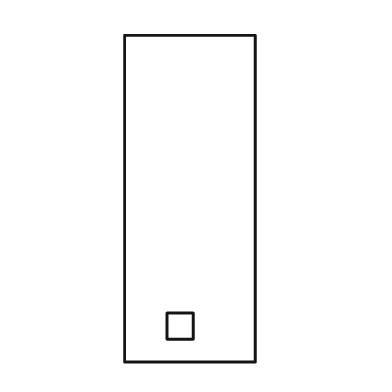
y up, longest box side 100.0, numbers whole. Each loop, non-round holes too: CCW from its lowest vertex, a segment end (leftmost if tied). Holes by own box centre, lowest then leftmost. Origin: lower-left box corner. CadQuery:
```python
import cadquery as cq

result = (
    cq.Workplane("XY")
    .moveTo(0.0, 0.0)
    .lineTo(40.0, 0.0)
    .lineTo(40.0, 100.0)
    .lineTo(0.0, 100.0)
    .close()
    .moveTo(13.0, 7.0)
    .lineTo(21.0, 7.0)
    .lineTo(21.0, 15.0)
    .lineTo(13.0, 15.0)
    .close()
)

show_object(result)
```